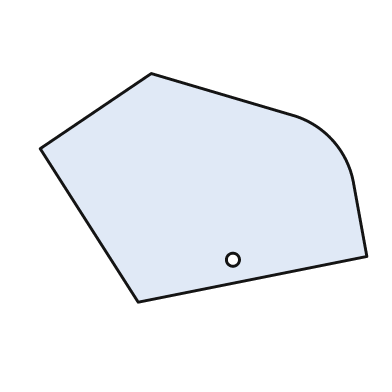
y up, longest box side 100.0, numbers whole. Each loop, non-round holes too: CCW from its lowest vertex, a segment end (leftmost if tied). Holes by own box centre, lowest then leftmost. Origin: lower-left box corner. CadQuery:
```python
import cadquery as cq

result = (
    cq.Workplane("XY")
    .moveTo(30.0, 0.0)
    .lineTo(100.0, 14.0)
    .lineTo(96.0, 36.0)
    .threePointArc((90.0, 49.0), (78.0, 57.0))
    .lineTo(34.0, 70.0)
    .lineTo(0.0, 47.0)
    .close()
    .moveTo(59.0, 13.0)
    .circle(2.0)
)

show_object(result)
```